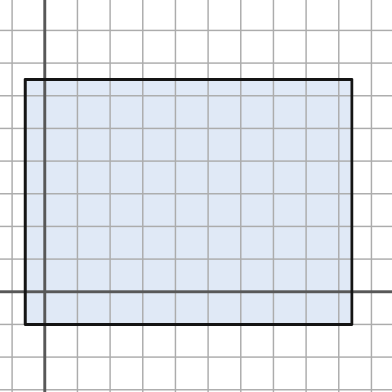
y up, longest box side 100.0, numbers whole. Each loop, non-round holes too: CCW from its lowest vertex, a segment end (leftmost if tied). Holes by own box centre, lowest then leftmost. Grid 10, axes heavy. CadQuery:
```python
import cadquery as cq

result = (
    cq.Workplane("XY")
    .moveTo(-6.0, -10.0)
    .lineTo(94.0, -10.0)
    .lineTo(94.0, 65.0)
    .lineTo(-6.0, 65.0)
    .close()
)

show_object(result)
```